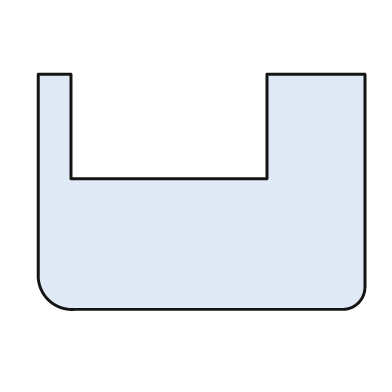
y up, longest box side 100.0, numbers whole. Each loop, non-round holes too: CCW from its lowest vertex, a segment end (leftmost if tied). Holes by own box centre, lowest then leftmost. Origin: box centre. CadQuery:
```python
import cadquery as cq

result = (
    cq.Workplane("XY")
    .moveTo(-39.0, -36.0)
    .lineTo(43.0, -36.0)
    .threePointArc((48.0, -34.0), (50.0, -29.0))
    .lineTo(50.0, 36.0)
    .lineTo(20.0, 36.0)
    .lineTo(20.0, 4.0)
    .lineTo(-40.0, 4.0)
    .lineTo(-40.0, 36.0)
    .lineTo(-50.0, 36.0)
    .lineTo(-50.0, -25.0)
    .threePointArc((-47.0, -33.0), (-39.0, -36.0))
    .close()
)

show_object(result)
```